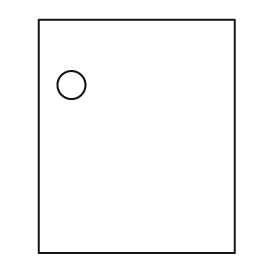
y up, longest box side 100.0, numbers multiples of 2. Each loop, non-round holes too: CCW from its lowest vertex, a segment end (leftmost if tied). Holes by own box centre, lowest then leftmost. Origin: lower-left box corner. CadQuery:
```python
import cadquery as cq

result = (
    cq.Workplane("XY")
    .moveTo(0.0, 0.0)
    .lineTo(84.0, 0.0)
    .lineTo(84.0, 100.0)
    .lineTo(0.0, 100.0)
    .close()
    .moveTo(14.0, 72.0)
    .circle(6.0)
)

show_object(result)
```